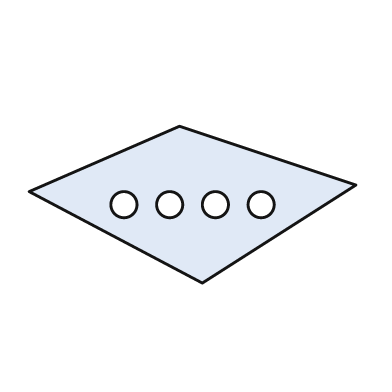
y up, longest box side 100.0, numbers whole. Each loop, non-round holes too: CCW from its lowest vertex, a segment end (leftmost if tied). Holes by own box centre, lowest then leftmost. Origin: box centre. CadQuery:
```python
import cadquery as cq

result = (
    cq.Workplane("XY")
    .moveTo(3.0, -24.0)
    .lineTo(50.0, 6.0)
    .lineTo(-4.0, 24.0)
    .lineTo(-50.0, 4.0)
    .close()
    .moveTo(-21.0, 0.0)
    .circle(4.0)
    .moveTo(-7.0, 0.0)
    .circle(4.0)
    .moveTo(7.0, 0.0)
    .circle(4.0)
    .moveTo(21.0, 0.0)
    .circle(4.0)
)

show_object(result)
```